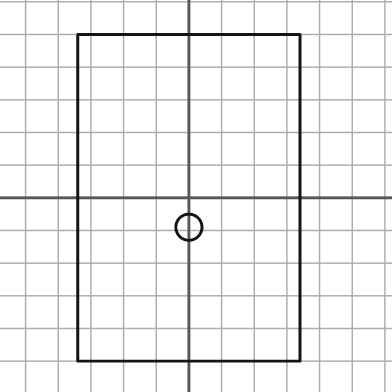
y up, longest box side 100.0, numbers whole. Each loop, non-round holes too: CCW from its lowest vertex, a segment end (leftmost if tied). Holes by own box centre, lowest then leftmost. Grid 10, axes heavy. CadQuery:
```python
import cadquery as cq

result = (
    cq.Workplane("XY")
    .moveTo(-34.0, -50.0)
    .lineTo(34.0, -50.0)
    .lineTo(34.0, 50.0)
    .lineTo(-34.0, 50.0)
    .close()
    .moveTo(0.0, -9.0)
    .circle(4.0)
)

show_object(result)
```